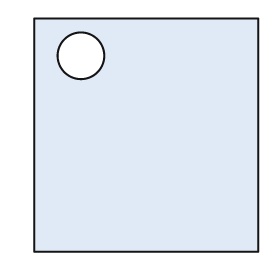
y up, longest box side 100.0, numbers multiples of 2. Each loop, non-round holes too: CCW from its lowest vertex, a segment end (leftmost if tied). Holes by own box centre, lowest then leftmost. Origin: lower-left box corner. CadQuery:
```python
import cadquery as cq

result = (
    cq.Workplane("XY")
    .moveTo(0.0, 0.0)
    .lineTo(96.0, 0.0)
    .lineTo(96.0, 100.0)
    .lineTo(0.0, 100.0)
    .close()
    .moveTo(20.0, 84.0)
    .circle(10.0)
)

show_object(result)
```